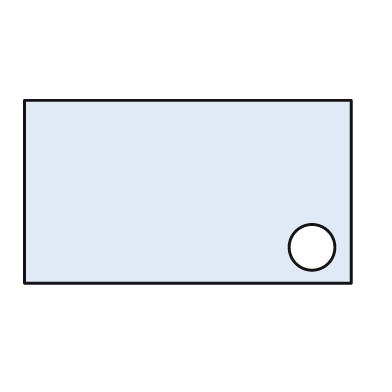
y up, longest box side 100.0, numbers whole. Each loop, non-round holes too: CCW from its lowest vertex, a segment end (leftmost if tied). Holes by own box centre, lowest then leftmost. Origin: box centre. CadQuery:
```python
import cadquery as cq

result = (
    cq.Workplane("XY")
    .moveTo(-50.0, -28.0)
    .lineTo(50.0, -28.0)
    .lineTo(50.0, 28.0)
    .lineTo(-50.0, 28.0)
    .close()
    .moveTo(38.0, -17.0)
    .circle(7.0)
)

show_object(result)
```